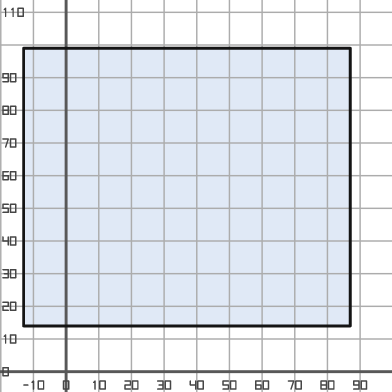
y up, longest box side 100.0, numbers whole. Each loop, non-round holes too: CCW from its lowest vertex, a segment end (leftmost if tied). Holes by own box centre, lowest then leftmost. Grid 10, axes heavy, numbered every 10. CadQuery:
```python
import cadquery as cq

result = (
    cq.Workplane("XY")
    .moveTo(-13.0, 14.0)
    .lineTo(87.0, 14.0)
    .lineTo(87.0, 99.0)
    .lineTo(-13.0, 99.0)
    .close()
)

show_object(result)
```